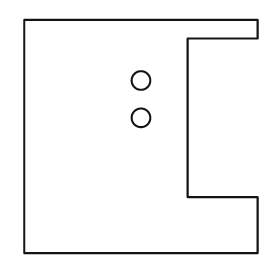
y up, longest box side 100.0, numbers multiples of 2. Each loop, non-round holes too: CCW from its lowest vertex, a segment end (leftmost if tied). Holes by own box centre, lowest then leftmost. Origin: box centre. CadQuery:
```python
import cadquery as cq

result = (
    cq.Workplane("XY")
    .moveTo(-50.0, -50.0)
    .lineTo(50.0, -50.0)
    .lineTo(50.0, -26.0)
    .lineTo(20.0, -26.0)
    .lineTo(20.0, 42.0)
    .lineTo(50.0, 42.0)
    .lineTo(50.0, 50.0)
    .lineTo(-50.0, 50.0)
    .close()
    .moveTo(0.0, 8.0)
    .circle(4.0)
    .moveTo(0.0, 24.0)
    .circle(4.0)
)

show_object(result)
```